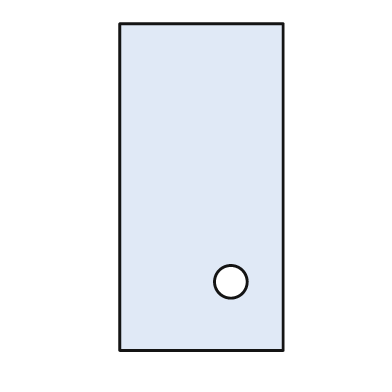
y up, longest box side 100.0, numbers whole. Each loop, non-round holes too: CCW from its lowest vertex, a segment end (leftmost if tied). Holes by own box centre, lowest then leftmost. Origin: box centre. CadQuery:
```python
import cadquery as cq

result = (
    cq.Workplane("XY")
    .moveTo(-25.0, -50.0)
    .lineTo(25.0, -50.0)
    .lineTo(25.0, 50.0)
    .lineTo(-25.0, 50.0)
    .close()
    .moveTo(9.0, -29.0)
    .circle(5.0)
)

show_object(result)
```